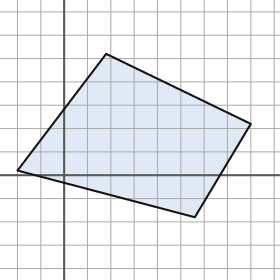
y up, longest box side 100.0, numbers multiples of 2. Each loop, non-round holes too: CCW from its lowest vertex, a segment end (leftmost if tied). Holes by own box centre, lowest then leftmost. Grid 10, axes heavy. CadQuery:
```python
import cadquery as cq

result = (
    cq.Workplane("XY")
    .moveTo(56.0, -18.0)
    .lineTo(80.0, 22.0)
    .lineTo(18.0, 52.0)
    .lineTo(-20.0, 2.0)
    .close()
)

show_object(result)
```